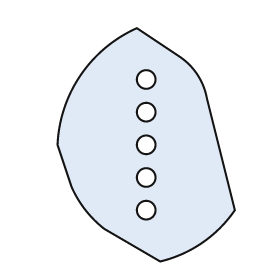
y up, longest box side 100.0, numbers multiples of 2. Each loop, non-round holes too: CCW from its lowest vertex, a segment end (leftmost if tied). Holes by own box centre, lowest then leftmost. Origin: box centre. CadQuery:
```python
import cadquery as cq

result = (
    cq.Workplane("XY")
    .moveTo(6.0, -50.0)
    .threePointArc((24.0, -42.0), (38.0, -28.0))
    .lineTo(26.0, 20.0)
    .threePointArc((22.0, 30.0), (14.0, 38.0))
    .lineTo(-4.0, 50.0)
    .threePointArc((-28.0, 30.0), (-38.0, 0.0))
    .lineTo(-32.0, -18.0)
    .threePointArc((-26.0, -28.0), (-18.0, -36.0))
    .close()
    .moveTo(0.0, -28.0)
    .circle(4.0)
    .moveTo(0.0, -14.0)
    .circle(4.0)
    .moveTo(0.0, 0.0)
    .circle(4.0)
    .moveTo(0.0, 14.0)
    .circle(4.0)
    .moveTo(0.0, 28.0)
    .circle(4.0)
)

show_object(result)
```